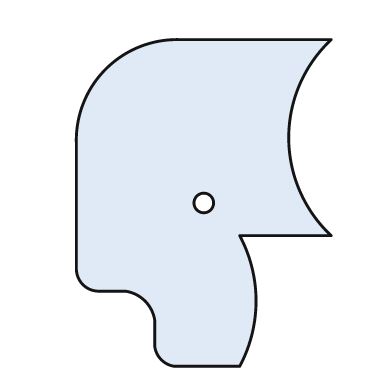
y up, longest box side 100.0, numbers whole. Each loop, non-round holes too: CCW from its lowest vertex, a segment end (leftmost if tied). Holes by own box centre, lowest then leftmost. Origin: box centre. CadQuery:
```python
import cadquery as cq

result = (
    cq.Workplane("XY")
    .moveTo(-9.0, -50.0)
    .lineTo(11.0, -50.0)
    .threePointArc((16.0, -30.0), (11.0, -10.0))
    .lineTo(39.0, -10.0)
    .threePointArc((26.0, 20.0), (39.0, 50.0))
    .lineTo(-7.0, 50.0)
    .threePointArc((-30.0, 41.0), (-39.0, 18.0))
    .lineTo(-39.0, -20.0)
    .threePointArc((-37.0, -25.0), (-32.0, -27.0))
    .lineTo(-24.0, -27.0)
    .threePointArc((-18.0, -30.0), (-15.0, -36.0))
    .lineTo(-15.0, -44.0)
    .threePointArc((-13.0, -48.0), (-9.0, -50.0))
    .close()
    .moveTo(0.0, 0.0)
    .circle(3.0)
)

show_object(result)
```